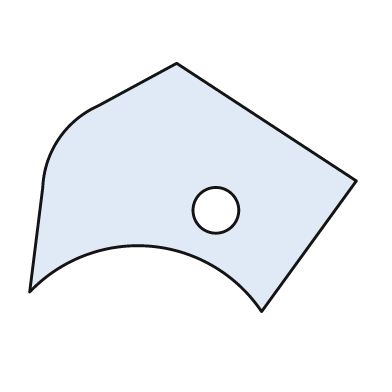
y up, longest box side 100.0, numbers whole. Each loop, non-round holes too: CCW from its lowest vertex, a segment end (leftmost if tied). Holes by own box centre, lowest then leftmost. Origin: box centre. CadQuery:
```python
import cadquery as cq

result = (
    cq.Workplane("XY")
    .moveTo(21.0, -38.0)
    .lineTo(50.0, 2.0)
    .lineTo(-5.0, 38.0)
    .lineTo(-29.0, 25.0)
    .threePointArc((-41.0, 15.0), (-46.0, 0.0))
    .lineTo(-50.0, -32.0)
    .threePointArc((-13.0, -18.0), (21.0, -38.0))
    .close()
    .moveTo(7.0, -7.0)
    .circle(7.0)
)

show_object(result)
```